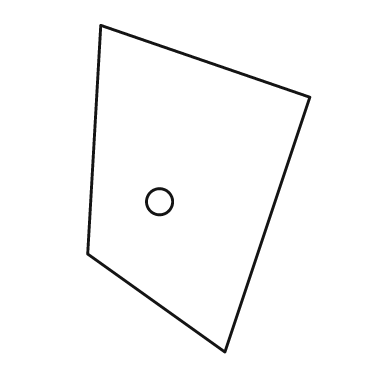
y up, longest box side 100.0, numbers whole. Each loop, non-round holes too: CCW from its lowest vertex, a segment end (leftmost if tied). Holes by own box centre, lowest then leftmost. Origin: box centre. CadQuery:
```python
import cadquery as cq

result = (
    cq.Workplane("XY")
    .moveTo(8.0, -50.0)
    .lineTo(34.0, 28.0)
    .lineTo(-30.0, 50.0)
    .lineTo(-34.0, -20.0)
    .close()
    .moveTo(-12.0, -4.0)
    .circle(4.0)
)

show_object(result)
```